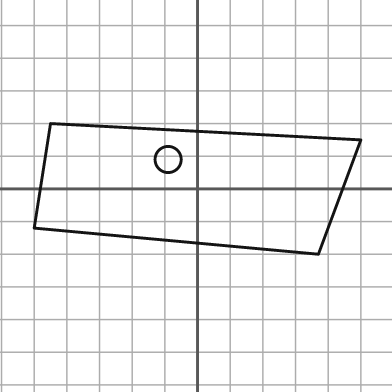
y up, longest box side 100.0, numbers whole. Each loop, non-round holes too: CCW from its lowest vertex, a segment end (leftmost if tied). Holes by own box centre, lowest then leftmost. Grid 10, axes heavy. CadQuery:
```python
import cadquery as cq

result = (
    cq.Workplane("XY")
    .moveTo(37.0, -20.0)
    .lineTo(50.0, 15.0)
    .lineTo(-45.0, 20.0)
    .lineTo(-50.0, -12.0)
    .close()
    .moveTo(-9.0, 9.0)
    .circle(4.0)
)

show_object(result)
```